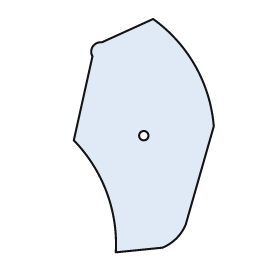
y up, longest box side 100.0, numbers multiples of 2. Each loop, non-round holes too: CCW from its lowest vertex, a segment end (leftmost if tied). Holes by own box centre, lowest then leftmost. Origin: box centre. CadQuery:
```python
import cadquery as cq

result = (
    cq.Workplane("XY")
    .moveTo(-12.0, -50.0)
    .lineTo(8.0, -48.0)
    .threePointArc((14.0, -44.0), (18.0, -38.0))
    .lineTo(30.0, 4.0)
    .threePointArc((22.0, 30.0), (4.0, 50.0))
    .lineTo(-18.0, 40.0)
    .threePointArc((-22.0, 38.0), (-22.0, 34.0))
    .lineTo(-30.0, -2.0)
    .threePointArc((-16.0, -24.0), (-12.0, -50.0))
    .close()
    .moveTo(0.0, 0.0)
    .circle(2.0)
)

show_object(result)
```